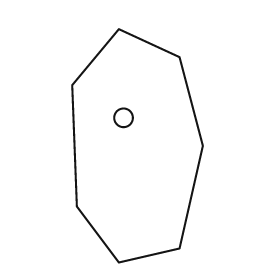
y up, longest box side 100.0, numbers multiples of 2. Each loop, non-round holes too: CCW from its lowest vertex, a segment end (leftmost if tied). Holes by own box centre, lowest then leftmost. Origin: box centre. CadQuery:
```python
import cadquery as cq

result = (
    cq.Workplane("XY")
    .moveTo(-8.0, -50.0)
    .lineTo(18.0, -44.0)
    .lineTo(28.0, 0.0)
    .lineTo(18.0, 38.0)
    .lineTo(-8.0, 50.0)
    .lineTo(-28.0, 26.0)
    .lineTo(-26.0, -26.0)
    .close()
    .moveTo(-6.0, 12.0)
    .circle(4.0)
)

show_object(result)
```